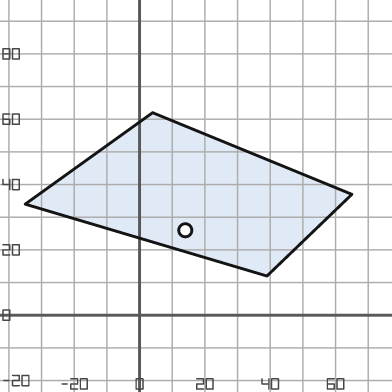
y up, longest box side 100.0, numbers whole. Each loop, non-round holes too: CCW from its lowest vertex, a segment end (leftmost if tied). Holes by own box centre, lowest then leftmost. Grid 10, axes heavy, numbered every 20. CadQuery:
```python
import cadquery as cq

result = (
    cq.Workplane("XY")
    .moveTo(39.0, 12.0)
    .lineTo(65.0, 37.0)
    .lineTo(4.0, 62.0)
    .lineTo(-35.0, 34.0)
    .close()
    .moveTo(14.0, 26.0)
    .circle(2.0)
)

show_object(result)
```